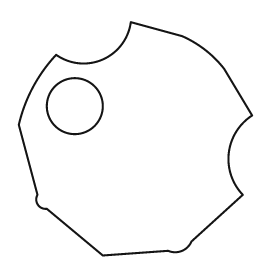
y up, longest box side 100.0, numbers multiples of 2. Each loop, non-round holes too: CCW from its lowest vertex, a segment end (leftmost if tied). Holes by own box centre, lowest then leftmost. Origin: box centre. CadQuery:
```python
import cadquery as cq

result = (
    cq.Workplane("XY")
    .moveTo(-14.0, -50.0)
    .lineTo(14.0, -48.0)
    .threePointArc((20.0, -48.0), (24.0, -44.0))
    .lineTo(46.0, -24.0)
    .threePointArc((40.0, -6.0), (50.0, 10.0))
    .lineTo(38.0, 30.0)
    .threePointArc((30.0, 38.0), (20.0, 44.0))
    .lineTo(-2.0, 50.0)
    .threePointArc((-14.0, 34.0), (-34.0, 36.0))
    .threePointArc((-44.0, 22.0), (-50.0, 6.0))
    .lineTo(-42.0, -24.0)
    .threePointArc((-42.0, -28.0), (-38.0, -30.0))
    .close()
    .moveTo(-26.0, 14.0)
    .circle(12.0)
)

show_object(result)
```